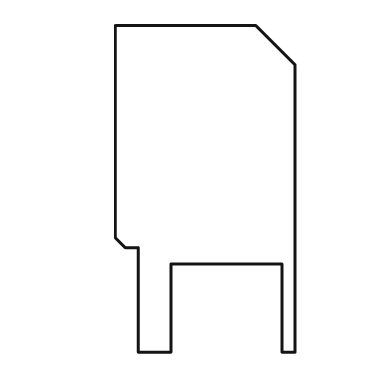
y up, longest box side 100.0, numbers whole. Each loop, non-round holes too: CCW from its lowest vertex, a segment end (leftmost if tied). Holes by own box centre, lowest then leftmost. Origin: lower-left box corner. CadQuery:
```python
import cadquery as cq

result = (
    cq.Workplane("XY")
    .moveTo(7.0, 0.0)
    .lineTo(17.0, 0.0)
    .lineTo(17.0, 27.0)
    .lineTo(51.0, 27.0)
    .lineTo(51.0, 0.0)
    .lineTo(55.0, 0.0)
    .lineTo(55.0, 88.0)
    .lineTo(43.0, 100.0)
    .lineTo(0.0, 100.0)
    .lineTo(0.0, 35.0)
    .lineTo(3.0, 32.0)
    .lineTo(7.0, 32.0)
    .close()
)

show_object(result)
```